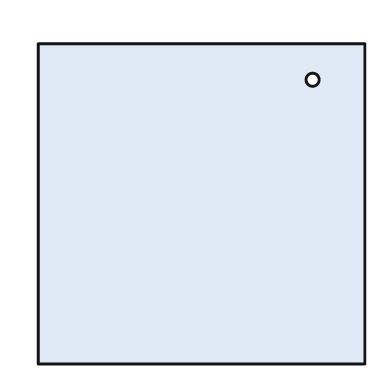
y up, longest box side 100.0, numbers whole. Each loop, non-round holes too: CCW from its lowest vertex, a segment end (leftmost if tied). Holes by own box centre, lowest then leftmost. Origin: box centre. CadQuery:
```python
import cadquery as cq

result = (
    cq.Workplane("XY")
    .moveTo(-50.0, -49.0)
    .lineTo(50.0, -49.0)
    .lineTo(50.0, 49.0)
    .lineTo(-50.0, 49.0)
    .close()
    .moveTo(34.0, 38.0)
    .circle(2.0)
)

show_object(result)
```